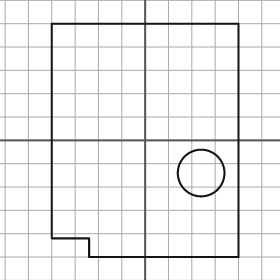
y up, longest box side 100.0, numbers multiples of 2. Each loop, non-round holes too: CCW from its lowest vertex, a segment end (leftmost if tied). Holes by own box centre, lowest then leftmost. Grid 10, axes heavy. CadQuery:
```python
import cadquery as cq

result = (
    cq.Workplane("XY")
    .moveTo(-24.0, -50.0)
    .lineTo(40.0, -50.0)
    .lineTo(40.0, 50.0)
    .lineTo(-40.0, 50.0)
    .lineTo(-40.0, -42.0)
    .lineTo(-24.0, -42.0)
    .close()
    .moveTo(24.0, -14.0)
    .circle(10.0)
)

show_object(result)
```